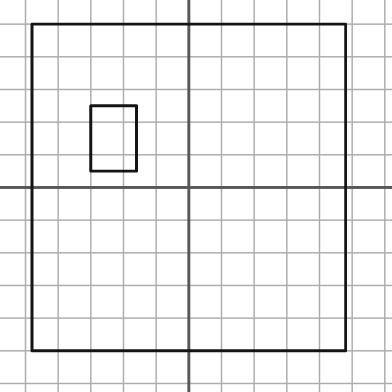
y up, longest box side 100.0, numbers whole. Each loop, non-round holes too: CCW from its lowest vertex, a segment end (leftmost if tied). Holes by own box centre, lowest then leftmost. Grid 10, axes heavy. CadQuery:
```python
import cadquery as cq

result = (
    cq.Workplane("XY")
    .moveTo(-48.0, -50.0)
    .lineTo(48.0, -50.0)
    .lineTo(48.0, 50.0)
    .lineTo(-48.0, 50.0)
    .close()
    .moveTo(-30.0, 5.0)
    .lineTo(-16.0, 5.0)
    .lineTo(-16.0, 25.0)
    .lineTo(-30.0, 25.0)
    .close()
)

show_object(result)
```